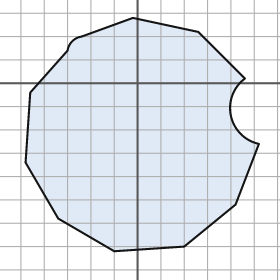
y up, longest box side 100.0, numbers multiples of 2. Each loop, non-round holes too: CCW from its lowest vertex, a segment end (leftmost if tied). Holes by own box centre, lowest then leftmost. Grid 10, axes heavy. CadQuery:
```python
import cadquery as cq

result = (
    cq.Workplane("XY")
    .moveTo(-10.0, -72.0)
    .lineTo(20.0, -70.0)
    .lineTo(42.0, -52.0)
    .lineTo(52.0, -26.0)
    .threePointArc((40.0, -14.0), (46.0, 2.0))
    .lineTo(26.0, 22.0)
    .lineTo(-2.0, 28.0)
    .lineTo(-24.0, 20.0)
    .threePointArc((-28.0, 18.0), (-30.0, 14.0))
    .lineTo(-46.0, -4.0)
    .lineTo(-48.0, -34.0)
    .lineTo(-34.0, -58.0)
    .close()
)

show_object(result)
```